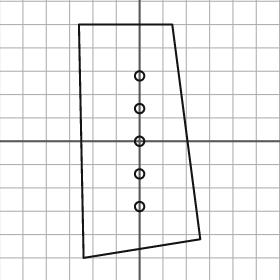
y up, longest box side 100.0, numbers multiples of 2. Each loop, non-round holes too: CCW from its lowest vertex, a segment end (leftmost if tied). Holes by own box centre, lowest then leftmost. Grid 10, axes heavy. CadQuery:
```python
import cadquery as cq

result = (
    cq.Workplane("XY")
    .moveTo(-24.0, -50.0)
    .lineTo(26.0, -42.0)
    .lineTo(14.0, 50.0)
    .lineTo(-26.0, 50.0)
    .close()
    .moveTo(0.0, -28.0)
    .circle(2.0)
    .moveTo(0.0, -14.0)
    .circle(2.0)
    .moveTo(0.0, 0.0)
    .circle(2.0)
    .moveTo(0.0, 14.0)
    .circle(2.0)
    .moveTo(0.0, 28.0)
    .circle(2.0)
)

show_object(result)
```